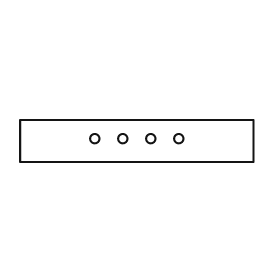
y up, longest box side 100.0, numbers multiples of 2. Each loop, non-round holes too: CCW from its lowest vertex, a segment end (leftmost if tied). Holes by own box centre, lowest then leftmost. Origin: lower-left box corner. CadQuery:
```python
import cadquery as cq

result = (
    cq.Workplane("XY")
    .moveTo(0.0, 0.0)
    .lineTo(100.0, 0.0)
    .lineTo(100.0, 18.0)
    .lineTo(0.0, 18.0)
    .close()
    .moveTo(32.0, 10.0)
    .circle(2.0)
    .moveTo(44.0, 10.0)
    .circle(2.0)
    .moveTo(56.0, 10.0)
    .circle(2.0)
    .moveTo(68.0, 10.0)
    .circle(2.0)
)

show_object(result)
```